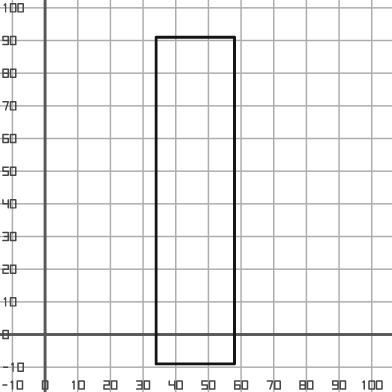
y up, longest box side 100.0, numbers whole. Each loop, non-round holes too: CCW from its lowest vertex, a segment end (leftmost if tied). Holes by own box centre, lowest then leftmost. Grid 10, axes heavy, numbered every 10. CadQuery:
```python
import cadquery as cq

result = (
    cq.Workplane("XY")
    .moveTo(34.0, -9.0)
    .lineTo(58.0, -9.0)
    .lineTo(58.0, 91.0)
    .lineTo(34.0, 91.0)
    .close()
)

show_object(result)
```